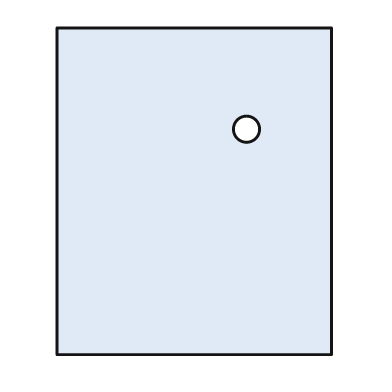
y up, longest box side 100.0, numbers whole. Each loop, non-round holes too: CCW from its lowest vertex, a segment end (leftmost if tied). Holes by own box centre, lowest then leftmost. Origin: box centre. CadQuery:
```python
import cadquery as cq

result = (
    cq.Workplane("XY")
    .moveTo(-42.0, -50.0)
    .lineTo(42.0, -50.0)
    .lineTo(42.0, 50.0)
    .lineTo(-42.0, 50.0)
    .close()
    .moveTo(16.0, 19.0)
    .circle(4.0)
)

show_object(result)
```